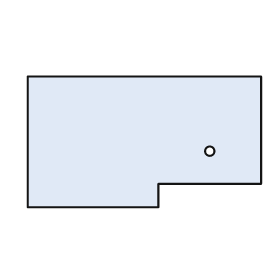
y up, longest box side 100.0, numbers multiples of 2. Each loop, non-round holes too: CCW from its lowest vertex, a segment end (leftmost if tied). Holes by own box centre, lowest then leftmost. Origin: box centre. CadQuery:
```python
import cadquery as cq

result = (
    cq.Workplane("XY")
    .moveTo(-50.0, -28.0)
    .lineTo(6.0, -28.0)
    .lineTo(6.0, -18.0)
    .lineTo(50.0, -18.0)
    .lineTo(50.0, 28.0)
    .lineTo(-50.0, 28.0)
    .close()
    .moveTo(28.0, -4.0)
    .circle(2.0)
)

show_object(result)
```